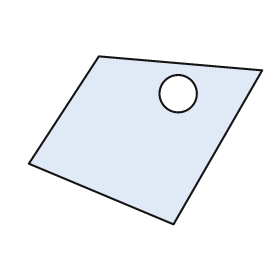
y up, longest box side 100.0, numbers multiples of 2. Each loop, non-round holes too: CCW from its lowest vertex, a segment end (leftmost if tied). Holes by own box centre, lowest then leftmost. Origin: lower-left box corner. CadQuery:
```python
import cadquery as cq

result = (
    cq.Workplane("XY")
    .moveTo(62.0, 0.0)
    .lineTo(100.0, 66.0)
    .lineTo(30.0, 72.0)
    .lineTo(0.0, 26.0)
    .close()
    .moveTo(64.0, 56.0)
    .circle(8.0)
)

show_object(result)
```